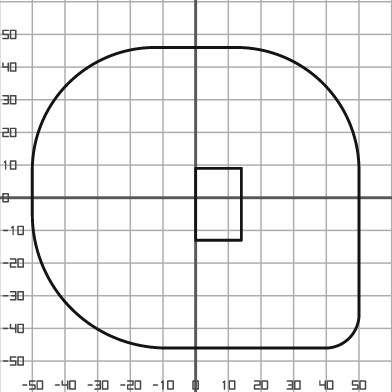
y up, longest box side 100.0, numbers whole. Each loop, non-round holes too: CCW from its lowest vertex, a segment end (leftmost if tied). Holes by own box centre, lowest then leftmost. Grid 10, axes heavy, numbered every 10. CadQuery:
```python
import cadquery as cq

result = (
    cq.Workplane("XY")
    .moveTo(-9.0, -46.0)
    .lineTo(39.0, -46.0)
    .threePointArc((47.0, -43.0), (50.0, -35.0))
    .lineTo(50.0, 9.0)
    .threePointArc((39.0, 35.0), (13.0, 46.0))
    .lineTo(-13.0, 46.0)
    .threePointArc((-39.0, 35.0), (-50.0, 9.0))
    .lineTo(-50.0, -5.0)
    .threePointArc((-38.0, -34.0), (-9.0, -46.0))
    .close()
    .moveTo(0.0, -13.0)
    .lineTo(14.0, -13.0)
    .lineTo(14.0, 9.0)
    .lineTo(0.0, 9.0)
    .close()
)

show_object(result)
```